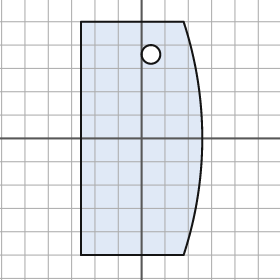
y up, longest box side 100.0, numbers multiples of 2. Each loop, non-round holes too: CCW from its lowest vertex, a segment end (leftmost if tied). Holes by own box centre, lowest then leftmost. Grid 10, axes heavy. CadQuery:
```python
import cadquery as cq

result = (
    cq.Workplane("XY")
    .moveTo(-26.0, -50.0)
    .lineTo(18.0, -50.0)
    .threePointArc((26.0, 0.0), (18.0, 50.0))
    .lineTo(-26.0, 50.0)
    .close()
    .moveTo(4.0, 36.0)
    .circle(4.0)
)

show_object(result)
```